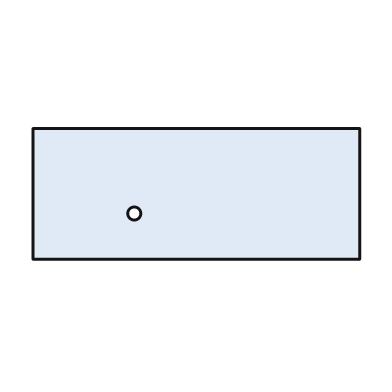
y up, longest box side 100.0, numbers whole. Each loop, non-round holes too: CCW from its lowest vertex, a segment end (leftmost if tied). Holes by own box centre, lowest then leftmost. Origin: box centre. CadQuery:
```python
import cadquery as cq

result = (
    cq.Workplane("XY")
    .moveTo(-50.0, -20.0)
    .lineTo(50.0, -20.0)
    .lineTo(50.0, 20.0)
    .lineTo(-50.0, 20.0)
    .close()
    .moveTo(-19.0, -6.0)
    .circle(2.0)
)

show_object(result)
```